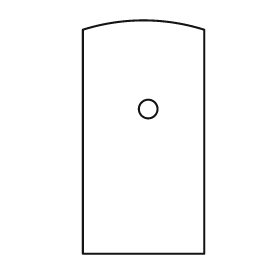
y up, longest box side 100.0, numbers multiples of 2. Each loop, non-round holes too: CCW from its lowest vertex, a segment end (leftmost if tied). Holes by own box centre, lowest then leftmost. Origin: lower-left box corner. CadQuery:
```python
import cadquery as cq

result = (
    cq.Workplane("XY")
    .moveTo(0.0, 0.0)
    .lineTo(52.0, 0.0)
    .lineTo(52.0, 96.0)
    .threePointArc((26.0, 100.0), (0.0, 96.0))
    .close()
    .moveTo(28.0, 62.0)
    .circle(4.0)
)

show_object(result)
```